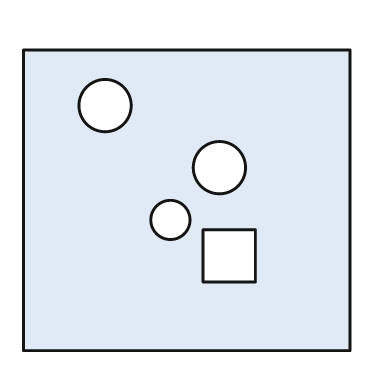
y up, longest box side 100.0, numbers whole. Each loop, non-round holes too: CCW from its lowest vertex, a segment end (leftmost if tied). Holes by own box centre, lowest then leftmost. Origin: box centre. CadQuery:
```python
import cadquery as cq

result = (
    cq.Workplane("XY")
    .moveTo(-50.0, -46.0)
    .lineTo(50.0, -46.0)
    .lineTo(50.0, 46.0)
    .lineTo(-50.0, 46.0)
    .close()
    .moveTo(5.0, -25.0)
    .lineTo(21.0, -25.0)
    .lineTo(21.0, -9.0)
    .lineTo(5.0, -9.0)
    .close()
    .moveTo(-5.0, -6.0)
    .circle(6.0)
    .moveTo(10.0, 10.0)
    .circle(8.0)
    .moveTo(-25.0, 29.0)
    .circle(8.0)
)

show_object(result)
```